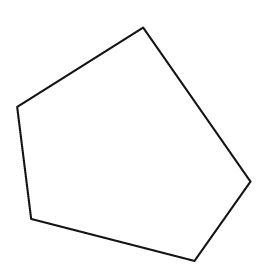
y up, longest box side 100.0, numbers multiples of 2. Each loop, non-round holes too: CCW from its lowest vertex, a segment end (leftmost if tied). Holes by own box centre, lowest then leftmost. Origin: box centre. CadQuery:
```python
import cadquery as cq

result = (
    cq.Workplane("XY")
    .moveTo(26.0, -50.0)
    .lineTo(50.0, -16.0)
    .lineTo(4.0, 50.0)
    .lineTo(-50.0, 16.0)
    .lineTo(-44.0, -32.0)
    .close()
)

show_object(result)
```